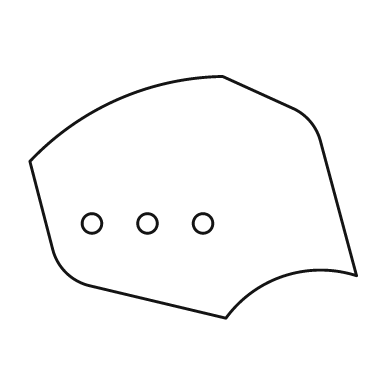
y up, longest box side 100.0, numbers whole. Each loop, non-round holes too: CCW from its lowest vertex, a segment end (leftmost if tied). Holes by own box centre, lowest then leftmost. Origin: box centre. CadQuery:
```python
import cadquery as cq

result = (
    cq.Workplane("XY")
    .moveTo(10.0, -37.0)
    .threePointArc((28.0, -24.0), (50.0, -24.0))
    .lineTo(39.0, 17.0)
    .threePointArc((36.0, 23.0), (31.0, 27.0))
    .lineTo(9.0, 37.0)
    .threePointArc((-23.0, 30.0), (-50.0, 11.0))
    .lineTo(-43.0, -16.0)
    .threePointArc((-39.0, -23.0), (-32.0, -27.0))
    .close()
    .moveTo(-31.0, -8.0)
    .circle(3.0)
    .moveTo(-14.0, -8.0)
    .circle(3.0)
    .moveTo(3.0, -8.0)
    .circle(3.0)
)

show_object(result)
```